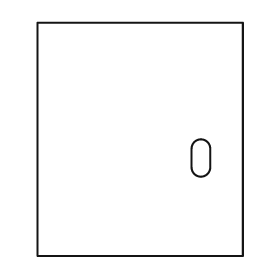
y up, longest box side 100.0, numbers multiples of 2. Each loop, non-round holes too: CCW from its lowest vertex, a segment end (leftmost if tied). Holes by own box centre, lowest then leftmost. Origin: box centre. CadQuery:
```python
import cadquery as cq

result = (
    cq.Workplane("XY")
    .moveTo(-44.0, -50.0)
    .lineTo(44.0, -50.0)
    .lineTo(44.0, 50.0)
    .lineTo(-44.0, 50.0)
    .close()
    .moveTo(22.0, -12.0)
    .threePointArc((26.0, -16.0), (30.0, -12.0))
    .lineTo(30.0, -4.0)
    .threePointArc((26.0, 0.0), (22.0, -4.0))
    .close()
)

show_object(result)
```